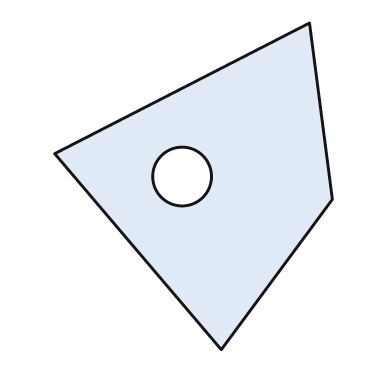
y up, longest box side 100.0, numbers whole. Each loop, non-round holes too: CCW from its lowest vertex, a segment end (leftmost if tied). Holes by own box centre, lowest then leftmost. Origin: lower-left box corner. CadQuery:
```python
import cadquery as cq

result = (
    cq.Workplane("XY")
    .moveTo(51.0, 0.0)
    .lineTo(85.0, 46.0)
    .lineTo(78.0, 100.0)
    .lineTo(0.0, 60.0)
    .close()
    .moveTo(39.0, 53.0)
    .circle(9.0)
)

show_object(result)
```